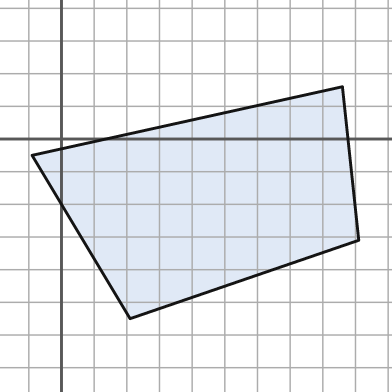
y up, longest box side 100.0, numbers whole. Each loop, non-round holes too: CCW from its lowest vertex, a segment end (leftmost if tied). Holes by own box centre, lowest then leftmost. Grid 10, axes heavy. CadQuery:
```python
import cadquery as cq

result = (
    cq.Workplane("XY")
    .moveTo(21.0, -55.0)
    .lineTo(91.0, -31.0)
    .lineTo(86.0, 16.0)
    .lineTo(-9.0, -5.0)
    .close()
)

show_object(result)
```